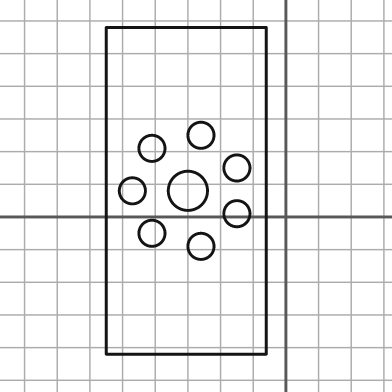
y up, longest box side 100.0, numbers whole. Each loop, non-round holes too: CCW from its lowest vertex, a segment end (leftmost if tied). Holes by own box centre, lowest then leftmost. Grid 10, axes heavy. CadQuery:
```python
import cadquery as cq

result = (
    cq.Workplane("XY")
    .moveTo(-55.0, -42.0)
    .lineTo(-6.0, -42.0)
    .lineTo(-6.0, 58.0)
    .lineTo(-55.0, 58.0)
    .close()
    .moveTo(-26.0, -9.0)
    .circle(4.0)
    .moveTo(-41.0, -5.0)
    .circle(4.0)
    .moveTo(-15.0, 1.0)
    .circle(4.0)
    .moveTo(-47.0, 8.0)
    .circle(4.0)
    .moveTo(-30.0, 8.0)
    .circle(6.0)
    .moveTo(-15.0, 15.0)
    .circle(4.0)
    .moveTo(-41.0, 21.0)
    .circle(4.0)
    .moveTo(-26.0, 25.0)
    .circle(4.0)
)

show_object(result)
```